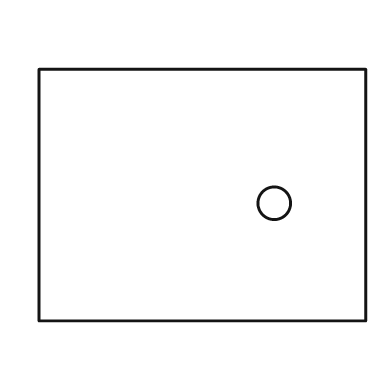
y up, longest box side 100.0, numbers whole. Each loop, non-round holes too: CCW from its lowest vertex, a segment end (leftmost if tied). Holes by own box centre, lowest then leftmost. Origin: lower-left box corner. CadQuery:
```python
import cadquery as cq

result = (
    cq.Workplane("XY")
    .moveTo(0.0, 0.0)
    .lineTo(100.0, 0.0)
    .lineTo(100.0, 77.0)
    .lineTo(0.0, 77.0)
    .close()
    .moveTo(72.0, 36.0)
    .circle(5.0)
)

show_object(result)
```